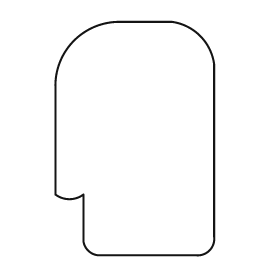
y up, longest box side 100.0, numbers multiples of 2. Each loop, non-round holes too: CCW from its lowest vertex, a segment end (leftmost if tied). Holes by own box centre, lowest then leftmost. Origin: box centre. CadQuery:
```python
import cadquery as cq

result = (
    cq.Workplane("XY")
    .moveTo(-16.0, -50.0)
    .lineTo(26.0, -50.0)
    .threePointArc((32.0, -48.0), (34.0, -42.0))
    .lineTo(34.0, 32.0)
    .threePointArc((28.0, 44.0), (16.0, 50.0))
    .lineTo(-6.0, 50.0)
    .threePointArc((-26.0, 42.0), (-34.0, 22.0))
    .lineTo(-34.0, -24.0)
    .threePointArc((-28.0, -26.0), (-22.0, -24.0))
    .lineTo(-22.0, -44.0)
    .threePointArc((-20.0, -48.0), (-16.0, -50.0))
    .close()
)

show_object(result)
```